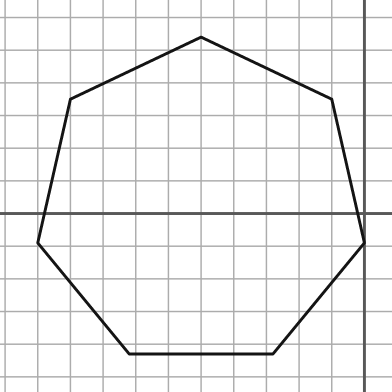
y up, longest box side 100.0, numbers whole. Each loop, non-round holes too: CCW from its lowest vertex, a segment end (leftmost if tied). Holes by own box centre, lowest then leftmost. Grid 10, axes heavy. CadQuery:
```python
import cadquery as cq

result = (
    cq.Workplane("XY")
    .moveTo(-72.0, -43.0)
    .lineTo(-28.0, -43.0)
    .lineTo(0.0, -9.0)
    .lineTo(-10.0, 35.0)
    .lineTo(-50.0, 54.0)
    .lineTo(-90.0, 35.0)
    .lineTo(-100.0, -9.0)
    .close()
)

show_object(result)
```